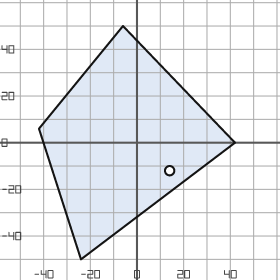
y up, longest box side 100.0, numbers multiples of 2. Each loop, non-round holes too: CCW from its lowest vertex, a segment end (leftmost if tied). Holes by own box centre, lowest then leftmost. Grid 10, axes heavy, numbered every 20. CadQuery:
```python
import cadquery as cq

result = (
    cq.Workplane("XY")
    .moveTo(-24.0, -50.0)
    .lineTo(42.0, 0.0)
    .lineTo(-6.0, 50.0)
    .lineTo(-42.0, 6.0)
    .close()
    .moveTo(14.0, -12.0)
    .circle(2.0)
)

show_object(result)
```